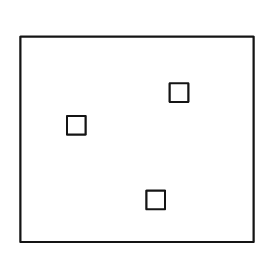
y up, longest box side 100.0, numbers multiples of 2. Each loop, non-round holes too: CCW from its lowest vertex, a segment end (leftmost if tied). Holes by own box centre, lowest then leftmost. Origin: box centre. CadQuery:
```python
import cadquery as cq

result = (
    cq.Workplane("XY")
    .moveTo(-50.0, -44.0)
    .lineTo(50.0, -44.0)
    .lineTo(50.0, 44.0)
    .lineTo(-50.0, 44.0)
    .close()
    .moveTo(4.0, -30.0)
    .lineTo(12.0, -30.0)
    .lineTo(12.0, -22.0)
    .lineTo(4.0, -22.0)
    .close()
    .moveTo(-30.0, 2.0)
    .lineTo(-22.0, 2.0)
    .lineTo(-22.0, 10.0)
    .lineTo(-30.0, 10.0)
    .close()
    .moveTo(14.0, 16.0)
    .lineTo(22.0, 16.0)
    .lineTo(22.0, 24.0)
    .lineTo(14.0, 24.0)
    .close()
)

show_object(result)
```